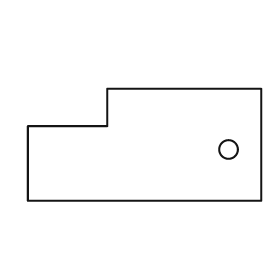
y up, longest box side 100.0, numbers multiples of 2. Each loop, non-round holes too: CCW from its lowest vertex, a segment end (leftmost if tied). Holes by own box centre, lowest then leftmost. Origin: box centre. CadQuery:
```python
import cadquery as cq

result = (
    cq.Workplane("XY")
    .moveTo(-50.0, -24.0)
    .lineTo(50.0, -24.0)
    .lineTo(50.0, 24.0)
    .lineTo(-16.0, 24.0)
    .lineTo(-16.0, 8.0)
    .lineTo(-50.0, 8.0)
    .close()
    .moveTo(36.0, -2.0)
    .circle(4.0)
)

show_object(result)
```